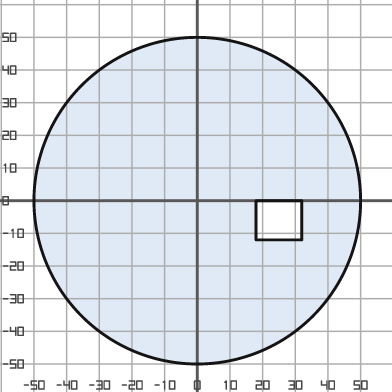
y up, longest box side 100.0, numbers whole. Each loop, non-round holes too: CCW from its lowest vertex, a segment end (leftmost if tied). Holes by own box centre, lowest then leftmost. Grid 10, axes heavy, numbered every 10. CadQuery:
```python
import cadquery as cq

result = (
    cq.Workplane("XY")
    .moveTo(0.0, 0.0)
    .circle(50.0)
    .moveTo(18.0, -12.0)
    .lineTo(32.0, -12.0)
    .lineTo(32.0, 0.0)
    .lineTo(18.0, 0.0)
    .close()
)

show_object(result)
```